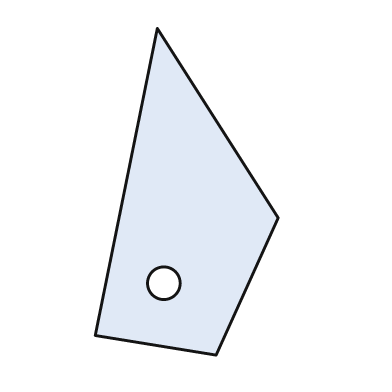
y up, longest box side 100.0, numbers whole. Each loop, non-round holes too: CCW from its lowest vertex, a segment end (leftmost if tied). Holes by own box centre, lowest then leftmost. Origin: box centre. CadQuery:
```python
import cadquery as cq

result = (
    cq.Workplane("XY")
    .moveTo(9.0, -50.0)
    .lineTo(28.0, -8.0)
    .lineTo(-9.0, 50.0)
    .lineTo(-28.0, -44.0)
    .close()
    .moveTo(-7.0, -28.0)
    .circle(5.0)
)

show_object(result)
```